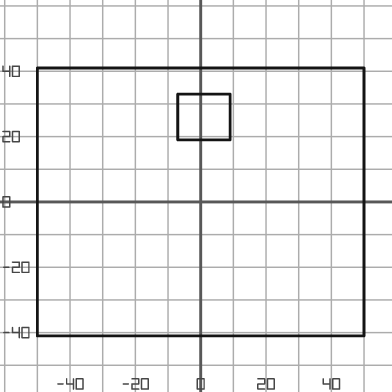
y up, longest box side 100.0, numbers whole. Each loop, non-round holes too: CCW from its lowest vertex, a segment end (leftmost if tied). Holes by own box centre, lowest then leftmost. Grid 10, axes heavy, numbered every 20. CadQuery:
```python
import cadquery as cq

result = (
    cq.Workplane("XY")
    .moveTo(-50.0, -41.0)
    .lineTo(50.0, -41.0)
    .lineTo(50.0, 41.0)
    .lineTo(-50.0, 41.0)
    .close()
    .moveTo(-7.0, 19.0)
    .lineTo(9.0, 19.0)
    .lineTo(9.0, 33.0)
    .lineTo(-7.0, 33.0)
    .close()
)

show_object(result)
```